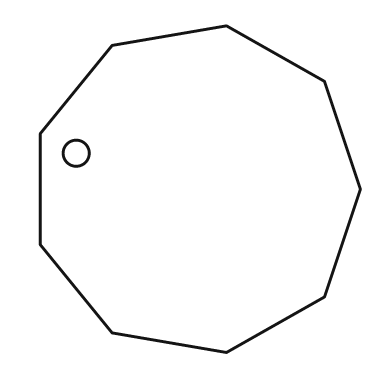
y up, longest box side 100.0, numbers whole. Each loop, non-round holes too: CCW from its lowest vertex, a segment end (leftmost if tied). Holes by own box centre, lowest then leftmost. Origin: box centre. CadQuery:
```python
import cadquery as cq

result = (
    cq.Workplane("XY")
    .moveTo(8.0, -50.0)
    .lineTo(38.0, -33.0)
    .lineTo(49.0, 0.0)
    .lineTo(38.0, 33.0)
    .lineTo(8.0, 50.0)
    .lineTo(-27.0, 44.0)
    .lineTo(-49.0, 17.0)
    .lineTo(-49.0, -17.0)
    .lineTo(-27.0, -44.0)
    .close()
    .moveTo(-38.0, 11.0)
    .circle(4.0)
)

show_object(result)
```